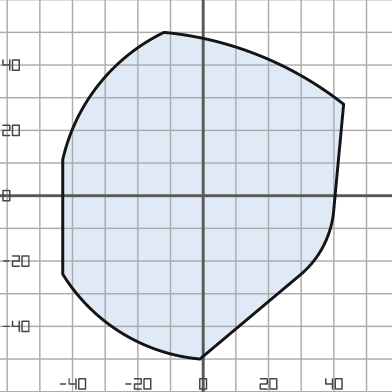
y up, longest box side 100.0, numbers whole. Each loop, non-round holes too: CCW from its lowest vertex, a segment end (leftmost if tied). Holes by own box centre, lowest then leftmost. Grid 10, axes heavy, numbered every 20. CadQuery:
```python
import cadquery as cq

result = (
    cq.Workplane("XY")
    .moveTo(-1.0, -50.0)
    .lineTo(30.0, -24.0)
    .threePointArc((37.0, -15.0), (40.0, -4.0))
    .lineTo(43.0, 28.0)
    .threePointArc((17.0, 43.0), (-12.0, 50.0))
    .threePointArc((-32.0, 34.0), (-43.0, 11.0))
    .lineTo(-43.0, -24.0)
    .threePointArc((-25.0, -42.0), (-1.0, -50.0))
    .close()
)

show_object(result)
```